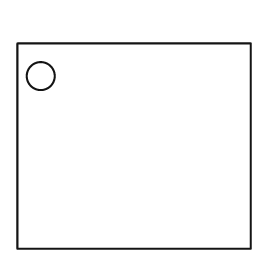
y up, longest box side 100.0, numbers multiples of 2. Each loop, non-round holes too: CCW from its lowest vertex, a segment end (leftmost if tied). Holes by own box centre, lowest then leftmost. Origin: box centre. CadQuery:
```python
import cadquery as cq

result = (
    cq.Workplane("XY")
    .moveTo(-50.0, -44.0)
    .lineTo(50.0, -44.0)
    .lineTo(50.0, 44.0)
    .lineTo(-50.0, 44.0)
    .close()
    .moveTo(-40.0, 30.0)
    .circle(6.0)
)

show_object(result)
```